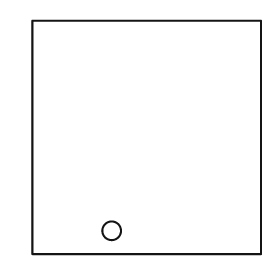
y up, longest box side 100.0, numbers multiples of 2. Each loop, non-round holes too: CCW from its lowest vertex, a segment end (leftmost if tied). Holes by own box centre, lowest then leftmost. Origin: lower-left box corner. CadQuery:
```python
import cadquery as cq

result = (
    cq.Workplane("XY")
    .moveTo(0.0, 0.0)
    .lineTo(98.0, 0.0)
    .lineTo(98.0, 100.0)
    .lineTo(0.0, 100.0)
    .close()
    .moveTo(34.0, 10.0)
    .circle(4.0)
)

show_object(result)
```